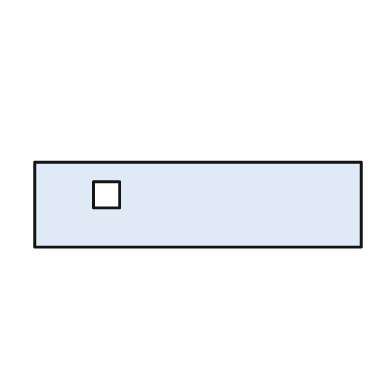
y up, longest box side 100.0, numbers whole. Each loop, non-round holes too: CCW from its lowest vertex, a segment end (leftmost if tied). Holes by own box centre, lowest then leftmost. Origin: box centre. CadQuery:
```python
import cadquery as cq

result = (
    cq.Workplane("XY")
    .moveTo(-50.0, -13.0)
    .lineTo(50.0, -13.0)
    .lineTo(50.0, 13.0)
    .lineTo(-50.0, 13.0)
    .close()
    .moveTo(-32.0, -1.0)
    .lineTo(-24.0, -1.0)
    .lineTo(-24.0, 7.0)
    .lineTo(-32.0, 7.0)
    .close()
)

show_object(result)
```